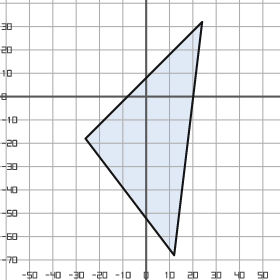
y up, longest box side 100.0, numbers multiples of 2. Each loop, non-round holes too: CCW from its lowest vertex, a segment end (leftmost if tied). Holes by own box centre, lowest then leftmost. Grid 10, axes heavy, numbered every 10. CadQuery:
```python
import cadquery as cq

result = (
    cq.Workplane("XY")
    .moveTo(12.0, -68.0)
    .lineTo(24.0, 32.0)
    .lineTo(-26.0, -18.0)
    .close()
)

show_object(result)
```